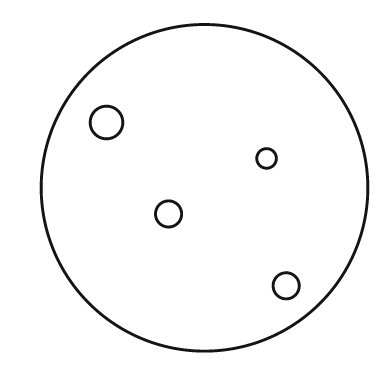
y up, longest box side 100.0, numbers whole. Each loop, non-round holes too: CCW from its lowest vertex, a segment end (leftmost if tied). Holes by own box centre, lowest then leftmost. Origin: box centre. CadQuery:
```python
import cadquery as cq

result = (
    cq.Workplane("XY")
    .moveTo(0.0, 0.0)
    .circle(50.0)
    .moveTo(25.0, -30.0)
    .circle(4.0)
    .moveTo(-11.0, -8.0)
    .circle(4.0)
    .moveTo(19.0, 9.0)
    .circle(3.0)
    .moveTo(-30.0, 20.0)
    .circle(5.0)
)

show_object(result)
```